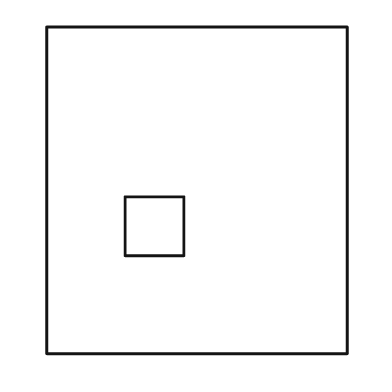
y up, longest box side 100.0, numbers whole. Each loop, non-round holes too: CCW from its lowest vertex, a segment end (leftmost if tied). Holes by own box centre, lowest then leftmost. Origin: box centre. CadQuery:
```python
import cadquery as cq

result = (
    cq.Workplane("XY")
    .moveTo(-46.0, -50.0)
    .lineTo(46.0, -50.0)
    .lineTo(46.0, 50.0)
    .lineTo(-46.0, 50.0)
    .close()
    .moveTo(-22.0, -20.0)
    .lineTo(-4.0, -20.0)
    .lineTo(-4.0, -2.0)
    .lineTo(-22.0, -2.0)
    .close()
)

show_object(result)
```